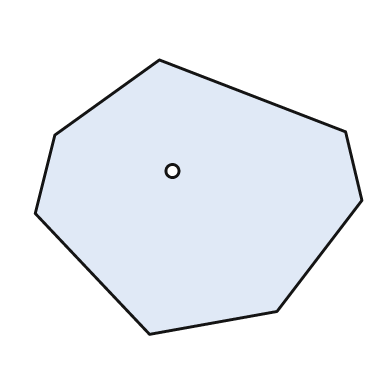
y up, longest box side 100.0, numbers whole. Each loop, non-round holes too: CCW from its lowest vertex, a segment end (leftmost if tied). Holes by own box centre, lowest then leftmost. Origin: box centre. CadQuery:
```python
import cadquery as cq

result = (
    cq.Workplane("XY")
    .moveTo(-15.0, -42.0)
    .lineTo(24.0, -35.0)
    .lineTo(50.0, -1.0)
    .lineTo(45.0, 20.0)
    .lineTo(-12.0, 42.0)
    .lineTo(-44.0, 19.0)
    .lineTo(-50.0, -5.0)
    .close()
    .moveTo(-8.0, 8.0)
    .circle(2.0)
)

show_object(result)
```